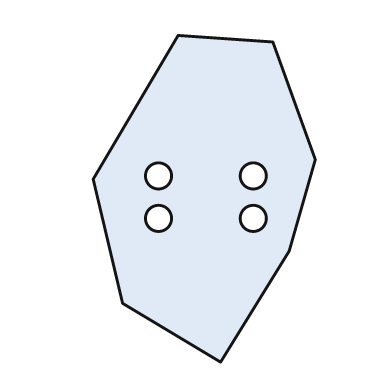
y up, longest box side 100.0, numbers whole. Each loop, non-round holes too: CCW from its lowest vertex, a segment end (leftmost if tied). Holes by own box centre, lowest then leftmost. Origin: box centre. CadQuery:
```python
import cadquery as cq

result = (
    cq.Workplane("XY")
    .moveTo(5.0, -50.0)
    .lineTo(26.0, -16.0)
    .lineTo(34.0, 12.0)
    .lineTo(21.0, 48.0)
    .lineTo(-8.0, 50.0)
    .lineTo(-34.0, 6.0)
    .lineTo(-25.0, -32.0)
    .close()
    .moveTo(-14.0, -6.0)
    .circle(4.0)
    .moveTo(15.0, -6.0)
    .circle(4.0)
    .moveTo(-14.0, 7.0)
    .circle(4.0)
    .moveTo(15.0, 7.0)
    .circle(4.0)
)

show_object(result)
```